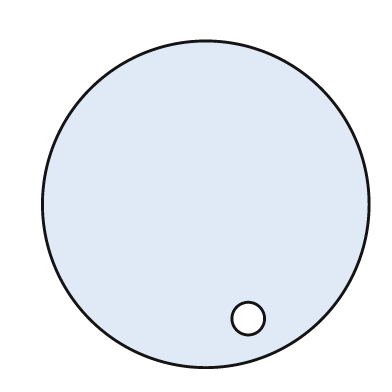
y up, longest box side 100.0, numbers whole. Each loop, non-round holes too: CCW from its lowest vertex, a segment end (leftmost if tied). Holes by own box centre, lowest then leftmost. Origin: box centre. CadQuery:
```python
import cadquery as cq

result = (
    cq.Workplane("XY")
    .moveTo(0.0, 0.0)
    .circle(50.0)
    .moveTo(13.0, -35.0)
    .circle(5.0)
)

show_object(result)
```